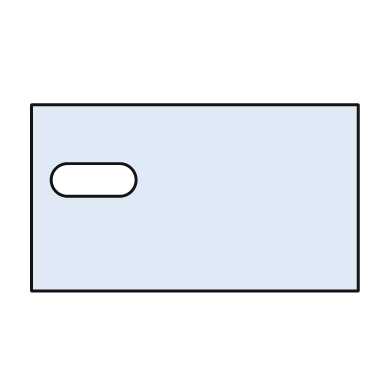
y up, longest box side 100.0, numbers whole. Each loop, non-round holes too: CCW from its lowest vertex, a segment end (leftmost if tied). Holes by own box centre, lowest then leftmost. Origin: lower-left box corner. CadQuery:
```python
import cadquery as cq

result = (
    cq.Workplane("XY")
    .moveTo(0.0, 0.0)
    .lineTo(100.0, 0.0)
    .lineTo(100.0, 57.0)
    .lineTo(0.0, 57.0)
    .close()
    .moveTo(11.0, 29.0)
    .lineTo(27.0, 29.0)
    .threePointArc((32.0, 34.0), (27.0, 39.0))
    .lineTo(11.0, 39.0)
    .threePointArc((6.0, 34.0), (11.0, 29.0))
    .close()
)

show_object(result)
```